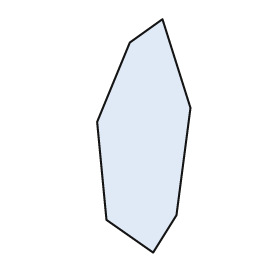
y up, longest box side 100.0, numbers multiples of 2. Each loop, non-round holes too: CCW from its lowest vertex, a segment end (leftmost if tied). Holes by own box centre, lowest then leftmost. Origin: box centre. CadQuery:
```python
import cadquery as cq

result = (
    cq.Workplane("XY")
    .moveTo(4.0, -50.0)
    .lineTo(14.0, -34.0)
    .lineTo(20.0, 12.0)
    .lineTo(8.0, 50.0)
    .lineTo(-6.0, 40.0)
    .lineTo(-20.0, 6.0)
    .lineTo(-16.0, -36.0)
    .close()
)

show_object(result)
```